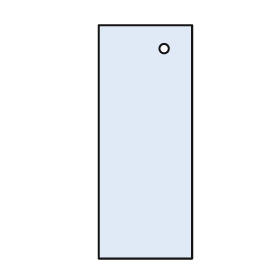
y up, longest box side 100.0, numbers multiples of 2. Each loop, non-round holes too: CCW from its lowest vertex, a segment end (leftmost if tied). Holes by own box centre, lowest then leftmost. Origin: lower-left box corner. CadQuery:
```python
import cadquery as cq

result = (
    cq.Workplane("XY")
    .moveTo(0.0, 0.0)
    .lineTo(40.0, 0.0)
    .lineTo(40.0, 100.0)
    .lineTo(0.0, 100.0)
    .close()
    .moveTo(28.0, 90.0)
    .circle(2.0)
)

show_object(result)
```